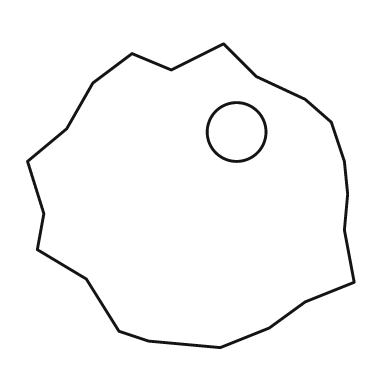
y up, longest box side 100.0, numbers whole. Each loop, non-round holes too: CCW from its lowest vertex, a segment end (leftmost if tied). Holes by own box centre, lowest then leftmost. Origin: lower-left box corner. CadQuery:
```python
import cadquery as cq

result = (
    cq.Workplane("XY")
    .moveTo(59.0, 0.0)
    .lineTo(74.0, 6.0)
    .lineTo(85.0, 14.0)
    .lineTo(100.0, 20.0)
    .lineTo(97.0, 36.0)
    .lineTo(98.0, 47.0)
    .lineTo(97.0, 57.0)
    .lineTo(93.0, 69.0)
    .lineTo(85.0, 76.0)
    .lineTo(70.0, 83.0)
    .lineTo(60.0, 93.0)
    .lineTo(44.0, 85.0)
    .lineTo(32.0, 90.0)
    .lineTo(20.0, 81.0)
    .lineTo(12.0, 67.0)
    .lineTo(0.0, 57.0)
    .lineTo(5.0, 41.0)
    .lineTo(3.0, 30.0)
    .lineTo(18.0, 21.0)
    .lineTo(28.0, 5.0)
    .lineTo(37.0, 2.0)
    .close()
    .moveTo(64.0, 66.0)
    .circle(9.0)
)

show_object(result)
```